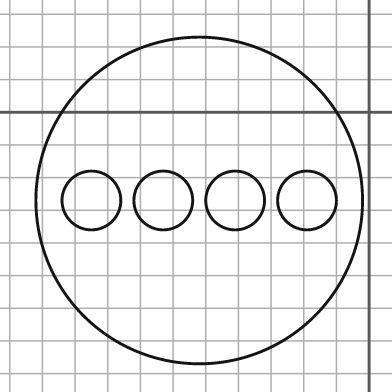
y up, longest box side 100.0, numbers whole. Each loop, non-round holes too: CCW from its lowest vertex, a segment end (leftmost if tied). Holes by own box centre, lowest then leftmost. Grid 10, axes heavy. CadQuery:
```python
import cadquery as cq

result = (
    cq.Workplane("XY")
    .moveTo(-52.0, -27.0)
    .circle(50.0)
    .moveTo(-85.0, -27.0)
    .circle(9.0)
    .moveTo(-63.0, -27.0)
    .circle(9.0)
    .moveTo(-41.0, -27.0)
    .circle(9.0)
    .moveTo(-19.0, -27.0)
    .circle(9.0)
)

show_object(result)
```